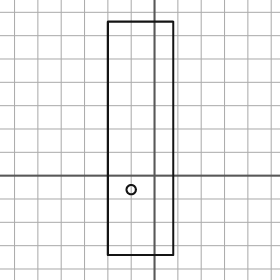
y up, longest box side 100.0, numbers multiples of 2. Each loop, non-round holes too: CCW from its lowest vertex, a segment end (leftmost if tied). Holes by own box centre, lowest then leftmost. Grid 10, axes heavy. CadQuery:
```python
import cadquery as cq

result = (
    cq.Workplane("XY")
    .moveTo(-20.0, -34.0)
    .lineTo(8.0, -34.0)
    .lineTo(8.0, 66.0)
    .lineTo(-20.0, 66.0)
    .close()
    .moveTo(-10.0, -6.0)
    .circle(2.0)
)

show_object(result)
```